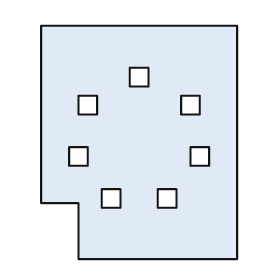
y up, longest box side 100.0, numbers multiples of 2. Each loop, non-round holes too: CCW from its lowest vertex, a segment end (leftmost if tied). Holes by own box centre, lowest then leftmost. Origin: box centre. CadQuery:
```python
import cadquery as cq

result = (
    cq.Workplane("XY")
    .moveTo(-26.0, -50.0)
    .lineTo(42.0, -50.0)
    .lineTo(42.0, 50.0)
    .lineTo(-42.0, 50.0)
    .lineTo(-42.0, -26.0)
    .lineTo(-26.0, -26.0)
    .close()
    .moveTo(-16.0, -28.0)
    .lineTo(-8.0, -28.0)
    .lineTo(-8.0, -20.0)
    .lineTo(-16.0, -20.0)
    .close()
    .moveTo(8.0, -28.0)
    .lineTo(16.0, -28.0)
    .lineTo(16.0, -20.0)
    .lineTo(8.0, -20.0)
    .close()
    .moveTo(-30.0, -10.0)
    .lineTo(-22.0, -10.0)
    .lineTo(-22.0, -2.0)
    .lineTo(-30.0, -2.0)
    .close()
    .moveTo(22.0, -10.0)
    .lineTo(30.0, -10.0)
    .lineTo(30.0, -2.0)
    .lineTo(22.0, -2.0)
    .close()
    .moveTo(-26.0, 12.0)
    .lineTo(-18.0, 12.0)
    .lineTo(-18.0, 20.0)
    .lineTo(-26.0, 20.0)
    .close()
    .moveTo(18.0, 12.0)
    .lineTo(26.0, 12.0)
    .lineTo(26.0, 20.0)
    .lineTo(18.0, 20.0)
    .close()
    .moveTo(-4.0, 24.0)
    .lineTo(4.0, 24.0)
    .lineTo(4.0, 32.0)
    .lineTo(-4.0, 32.0)
    .close()
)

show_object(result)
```